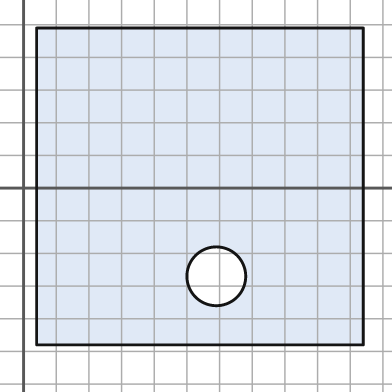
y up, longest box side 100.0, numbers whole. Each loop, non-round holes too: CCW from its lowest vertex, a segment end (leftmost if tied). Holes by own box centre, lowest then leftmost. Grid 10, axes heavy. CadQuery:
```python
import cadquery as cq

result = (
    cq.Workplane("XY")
    .moveTo(4.0, -48.0)
    .lineTo(104.0, -48.0)
    .lineTo(104.0, 49.0)
    .lineTo(4.0, 49.0)
    .close()
    .moveTo(59.0, -27.0)
    .circle(9.0)
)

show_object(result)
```